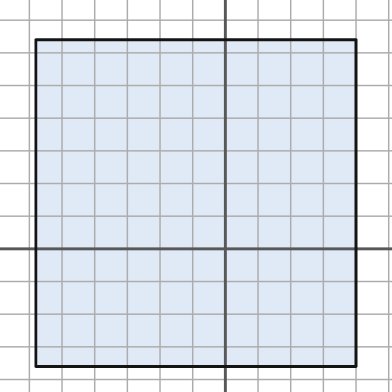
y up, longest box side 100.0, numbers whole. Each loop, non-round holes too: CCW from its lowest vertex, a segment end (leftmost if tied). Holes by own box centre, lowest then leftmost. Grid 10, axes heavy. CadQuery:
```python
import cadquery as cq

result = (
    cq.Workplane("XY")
    .moveTo(-58.0, -36.0)
    .lineTo(40.0, -36.0)
    .lineTo(40.0, 64.0)
    .lineTo(-58.0, 64.0)
    .close()
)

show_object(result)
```